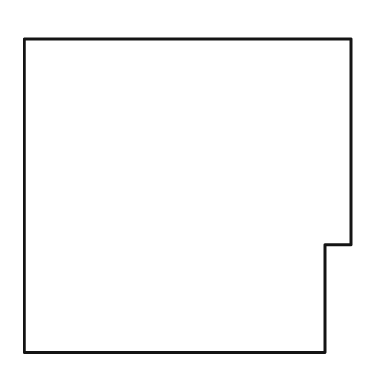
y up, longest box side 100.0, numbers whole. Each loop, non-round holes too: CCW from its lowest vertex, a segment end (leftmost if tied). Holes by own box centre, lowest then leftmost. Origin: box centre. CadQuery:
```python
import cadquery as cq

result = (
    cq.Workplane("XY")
    .moveTo(-50.0, -48.0)
    .lineTo(42.0, -48.0)
    .lineTo(42.0, -15.0)
    .lineTo(50.0, -15.0)
    .lineTo(50.0, 48.0)
    .lineTo(-50.0, 48.0)
    .close()
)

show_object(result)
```